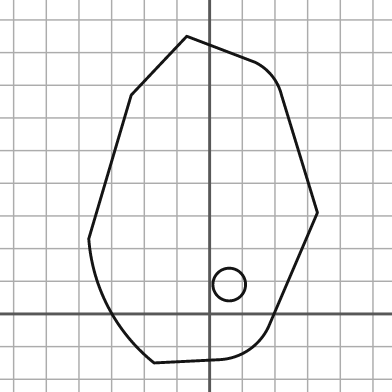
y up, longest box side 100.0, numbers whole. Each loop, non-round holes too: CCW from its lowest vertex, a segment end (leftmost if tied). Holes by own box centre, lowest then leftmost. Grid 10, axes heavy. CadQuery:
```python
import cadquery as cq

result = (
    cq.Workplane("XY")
    .moveTo(-17.0, -15.0)
    .lineTo(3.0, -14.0)
    .threePointArc((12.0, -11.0), (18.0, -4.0))
    .lineTo(33.0, 31.0)
    .lineTo(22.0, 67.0)
    .threePointArc((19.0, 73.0), (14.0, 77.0))
    .lineTo(-7.0, 85.0)
    .lineTo(-24.0, 67.0)
    .lineTo(-37.0, 23.0)
    .threePointArc((-31.0, 2.0), (-17.0, -15.0))
    .close()
    .moveTo(6.0, 9.0)
    .circle(5.0)
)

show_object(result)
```